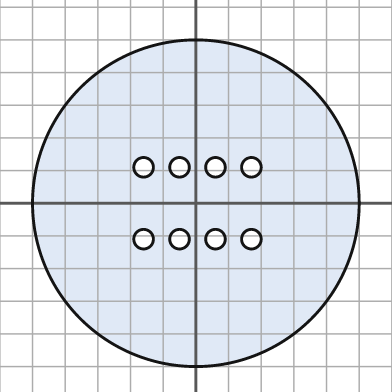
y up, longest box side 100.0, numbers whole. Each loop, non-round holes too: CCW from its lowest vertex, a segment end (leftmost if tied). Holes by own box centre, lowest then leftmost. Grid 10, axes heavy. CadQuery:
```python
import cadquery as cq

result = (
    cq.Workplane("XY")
    .moveTo(0.0, 0.0)
    .circle(50.0)
    .moveTo(-16.0, -11.0)
    .circle(3.0)
    .moveTo(-5.0, -11.0)
    .circle(3.0)
    .moveTo(6.0, -11.0)
    .circle(3.0)
    .moveTo(17.0, -11.0)
    .circle(3.0)
    .moveTo(-16.0, 11.0)
    .circle(3.0)
    .moveTo(-5.0, 11.0)
    .circle(3.0)
    .moveTo(6.0, 11.0)
    .circle(3.0)
    .moveTo(17.0, 11.0)
    .circle(3.0)
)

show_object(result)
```